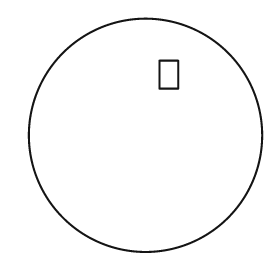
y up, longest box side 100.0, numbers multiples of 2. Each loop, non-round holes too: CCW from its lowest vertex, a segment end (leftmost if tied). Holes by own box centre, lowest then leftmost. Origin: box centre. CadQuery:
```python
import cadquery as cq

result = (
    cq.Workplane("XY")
    .moveTo(0.0, 0.0)
    .circle(50.0)
    .moveTo(6.0, 20.0)
    .lineTo(14.0, 20.0)
    .lineTo(14.0, 32.0)
    .lineTo(6.0, 32.0)
    .close()
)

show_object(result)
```